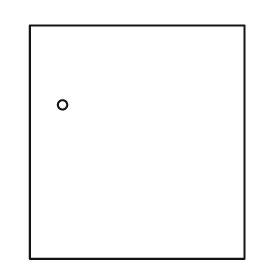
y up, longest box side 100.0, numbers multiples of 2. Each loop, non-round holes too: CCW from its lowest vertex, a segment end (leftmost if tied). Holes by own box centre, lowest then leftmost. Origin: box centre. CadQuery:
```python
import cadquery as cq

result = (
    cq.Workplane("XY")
    .moveTo(-46.0, -50.0)
    .lineTo(46.0, -50.0)
    .lineTo(46.0, 50.0)
    .lineTo(-46.0, 50.0)
    .close()
    .moveTo(-32.0, 16.0)
    .circle(2.0)
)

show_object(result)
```